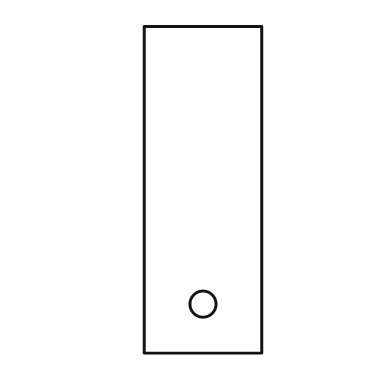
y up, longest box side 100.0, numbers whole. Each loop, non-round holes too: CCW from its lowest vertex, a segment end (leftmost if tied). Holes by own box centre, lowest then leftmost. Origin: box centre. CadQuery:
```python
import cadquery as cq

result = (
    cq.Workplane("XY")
    .moveTo(-18.0, -50.0)
    .lineTo(18.0, -50.0)
    .lineTo(18.0, 50.0)
    .lineTo(-18.0, 50.0)
    .close()
    .moveTo(0.0, -35.0)
    .circle(4.0)
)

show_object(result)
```